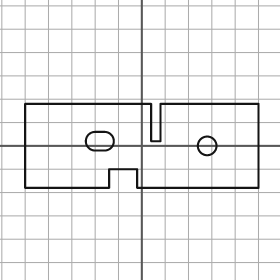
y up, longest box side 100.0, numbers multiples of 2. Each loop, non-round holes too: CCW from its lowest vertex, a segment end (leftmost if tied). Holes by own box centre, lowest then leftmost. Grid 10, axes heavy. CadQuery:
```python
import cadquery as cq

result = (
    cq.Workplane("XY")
    .moveTo(-50.0, -18.0)
    .lineTo(-14.0, -18.0)
    .lineTo(-14.0, -10.0)
    .lineTo(-2.0, -10.0)
    .lineTo(-2.0, -18.0)
    .lineTo(50.0, -18.0)
    .lineTo(50.0, 18.0)
    .lineTo(8.0, 18.0)
    .lineTo(8.0, 2.0)
    .lineTo(4.0, 2.0)
    .lineTo(4.0, 18.0)
    .lineTo(-50.0, 18.0)
    .close()
    .moveTo(28.0, 0.0)
    .circle(4.0)
    .moveTo(-20.0, -2.0)
    .lineTo(-16.0, -2.0)
    .threePointArc((-12.0, 2.0), (-16.0, 6.0))
    .lineTo(-20.0, 6.0)
    .threePointArc((-24.0, 2.0), (-20.0, -2.0))
    .close()
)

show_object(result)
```